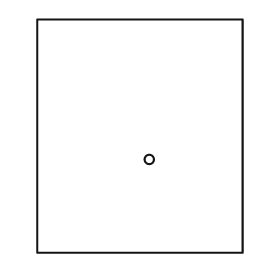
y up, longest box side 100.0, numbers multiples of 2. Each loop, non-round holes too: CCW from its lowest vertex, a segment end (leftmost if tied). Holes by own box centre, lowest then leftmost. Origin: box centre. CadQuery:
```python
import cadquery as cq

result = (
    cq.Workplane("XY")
    .moveTo(-44.0, -50.0)
    .lineTo(44.0, -50.0)
    .lineTo(44.0, 50.0)
    .lineTo(-44.0, 50.0)
    .close()
    .moveTo(4.0, -10.0)
    .circle(2.0)
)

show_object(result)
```